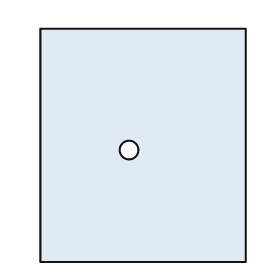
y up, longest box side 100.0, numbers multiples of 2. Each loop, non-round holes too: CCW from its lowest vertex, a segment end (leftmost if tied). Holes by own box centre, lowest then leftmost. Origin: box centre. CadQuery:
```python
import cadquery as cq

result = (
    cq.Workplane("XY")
    .moveTo(-44.0, -50.0)
    .lineTo(44.0, -50.0)
    .lineTo(44.0, 50.0)
    .lineTo(-44.0, 50.0)
    .close()
    .moveTo(-6.0, -2.0)
    .circle(4.0)
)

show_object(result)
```